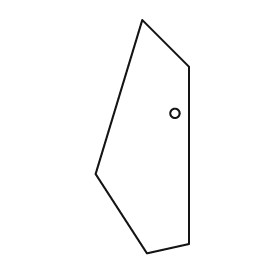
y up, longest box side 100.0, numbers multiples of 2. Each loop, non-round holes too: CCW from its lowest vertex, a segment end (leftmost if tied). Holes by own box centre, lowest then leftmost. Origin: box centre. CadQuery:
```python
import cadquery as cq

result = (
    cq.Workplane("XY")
    .moveTo(2.0, -50.0)
    .lineTo(20.0, -46.0)
    .lineTo(20.0, 30.0)
    .lineTo(0.0, 50.0)
    .lineTo(-20.0, -16.0)
    .close()
    .moveTo(14.0, 10.0)
    .circle(2.0)
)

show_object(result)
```